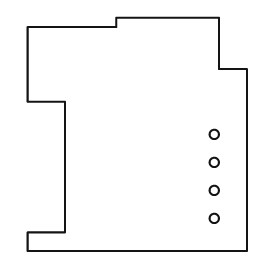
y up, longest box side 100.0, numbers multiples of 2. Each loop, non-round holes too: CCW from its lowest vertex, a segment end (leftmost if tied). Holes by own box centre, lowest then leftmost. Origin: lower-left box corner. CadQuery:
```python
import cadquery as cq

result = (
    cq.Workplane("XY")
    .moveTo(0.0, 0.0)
    .lineTo(94.0, 0.0)
    .lineTo(94.0, 78.0)
    .lineTo(82.0, 78.0)
    .lineTo(82.0, 100.0)
    .lineTo(38.0, 100.0)
    .lineTo(38.0, 96.0)
    .lineTo(0.0, 96.0)
    .lineTo(0.0, 64.0)
    .lineTo(16.0, 64.0)
    .lineTo(16.0, 8.0)
    .lineTo(0.0, 8.0)
    .close()
    .moveTo(80.0, 14.0)
    .circle(2.0)
    .moveTo(80.0, 26.0)
    .circle(2.0)
    .moveTo(80.0, 38.0)
    .circle(2.0)
    .moveTo(80.0, 50.0)
    .circle(2.0)
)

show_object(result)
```